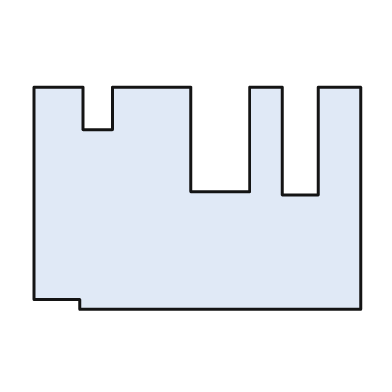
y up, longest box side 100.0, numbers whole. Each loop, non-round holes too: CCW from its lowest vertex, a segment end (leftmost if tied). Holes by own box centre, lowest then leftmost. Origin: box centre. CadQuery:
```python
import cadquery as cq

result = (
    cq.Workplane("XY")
    .moveTo(-36.0, -34.0)
    .lineTo(50.0, -34.0)
    .lineTo(50.0, 34.0)
    .lineTo(37.0, 34.0)
    .lineTo(37.0, 1.0)
    .lineTo(26.0, 1.0)
    .lineTo(26.0, 34.0)
    .lineTo(16.0, 34.0)
    .lineTo(16.0, 2.0)
    .lineTo(-2.0, 2.0)
    .lineTo(-2.0, 34.0)
    .lineTo(-26.0, 34.0)
    .lineTo(-26.0, 21.0)
    .lineTo(-35.0, 21.0)
    .lineTo(-35.0, 34.0)
    .lineTo(-50.0, 34.0)
    .lineTo(-50.0, -31.0)
    .lineTo(-36.0, -31.0)
    .close()
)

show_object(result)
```